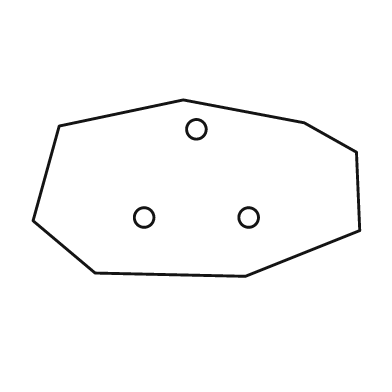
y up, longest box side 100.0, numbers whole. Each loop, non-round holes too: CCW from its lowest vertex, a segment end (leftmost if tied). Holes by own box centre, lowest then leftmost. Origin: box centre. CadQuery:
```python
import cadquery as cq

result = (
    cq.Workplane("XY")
    .moveTo(15.0, -27.0)
    .lineTo(50.0, -13.0)
    .lineTo(49.0, 11.0)
    .lineTo(33.0, 20.0)
    .lineTo(-4.0, 27.0)
    .lineTo(-42.0, 19.0)
    .lineTo(-50.0, -10.0)
    .lineTo(-31.0, -26.0)
    .close()
    .moveTo(-16.0, -9.0)
    .circle(3.0)
    .moveTo(16.0, -9.0)
    .circle(3.0)
    .moveTo(0.0, 18.0)
    .circle(3.0)
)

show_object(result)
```